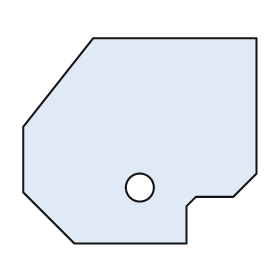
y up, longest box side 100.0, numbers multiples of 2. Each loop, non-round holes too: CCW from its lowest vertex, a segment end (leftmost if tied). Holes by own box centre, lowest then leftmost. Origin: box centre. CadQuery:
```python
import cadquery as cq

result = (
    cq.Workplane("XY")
    .moveTo(-28.0, -44.0)
    .lineTo(20.0, -44.0)
    .lineTo(20.0, -28.0)
    .lineTo(24.0, -24.0)
    .lineTo(40.0, -24.0)
    .lineTo(50.0, -14.0)
    .lineTo(50.0, 44.0)
    .lineTo(-20.0, 44.0)
    .lineTo(-50.0, 6.0)
    .lineTo(-50.0, -22.0)
    .close()
    .moveTo(0.0, -20.0)
    .circle(6.0)
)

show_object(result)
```